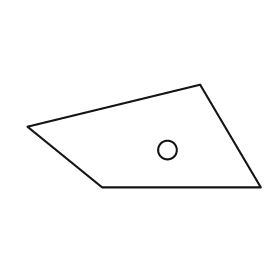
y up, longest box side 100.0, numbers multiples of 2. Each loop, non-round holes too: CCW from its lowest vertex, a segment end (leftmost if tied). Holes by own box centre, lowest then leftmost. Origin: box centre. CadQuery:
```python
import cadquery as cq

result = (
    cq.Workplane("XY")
    .moveTo(-18.0, -22.0)
    .lineTo(50.0, -22.0)
    .lineTo(24.0, 22.0)
    .lineTo(-50.0, 4.0)
    .close()
    .moveTo(10.0, -6.0)
    .circle(4.0)
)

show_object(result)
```